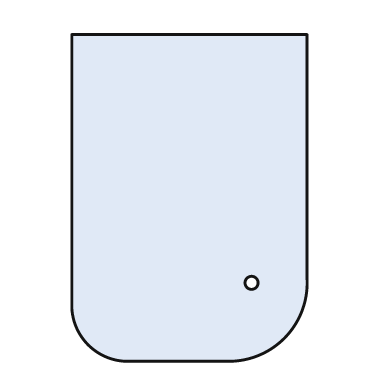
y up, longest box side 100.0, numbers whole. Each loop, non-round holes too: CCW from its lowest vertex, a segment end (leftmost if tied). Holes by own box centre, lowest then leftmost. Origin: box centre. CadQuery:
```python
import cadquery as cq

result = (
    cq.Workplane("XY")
    .moveTo(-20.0, -50.0)
    .lineTo(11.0, -50.0)
    .threePointArc((29.0, -43.0), (36.0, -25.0))
    .lineTo(36.0, 50.0)
    .lineTo(-36.0, 50.0)
    .lineTo(-36.0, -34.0)
    .threePointArc((-31.0, -45.0), (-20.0, -50.0))
    .close()
    .moveTo(19.0, -26.0)
    .circle(2.0)
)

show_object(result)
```